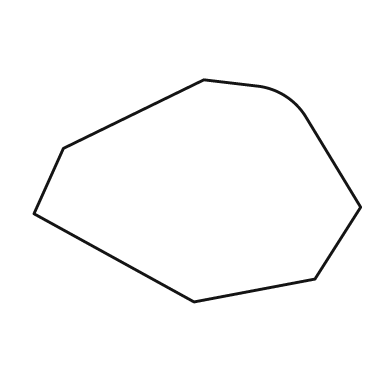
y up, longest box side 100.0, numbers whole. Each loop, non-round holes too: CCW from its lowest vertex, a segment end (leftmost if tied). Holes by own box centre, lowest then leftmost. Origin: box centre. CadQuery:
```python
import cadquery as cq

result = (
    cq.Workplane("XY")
    .moveTo(-1.0, -34.0)
    .lineTo(36.0, -27.0)
    .lineTo(50.0, -5.0)
    .lineTo(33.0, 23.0)
    .threePointArc((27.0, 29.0), (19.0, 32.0))
    .lineTo(2.0, 34.0)
    .lineTo(-41.0, 13.0)
    .lineTo(-50.0, -7.0)
    .close()
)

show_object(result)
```